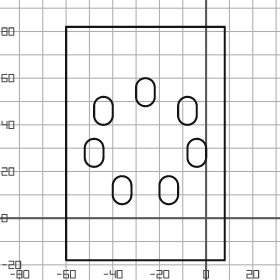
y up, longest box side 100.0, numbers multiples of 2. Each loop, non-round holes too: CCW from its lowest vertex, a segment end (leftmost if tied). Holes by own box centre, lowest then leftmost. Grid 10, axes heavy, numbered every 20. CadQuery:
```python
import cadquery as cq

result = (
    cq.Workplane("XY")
    .moveTo(-60.0, -18.0)
    .lineTo(8.0, -18.0)
    .lineTo(8.0, 82.0)
    .lineTo(-60.0, 82.0)
    .close()
    .moveTo(-40.0, 10.0)
    .threePointArc((-36.0, 6.0), (-32.0, 10.0))
    .lineTo(-32.0, 14.0)
    .threePointArc((-36.0, 18.0), (-40.0, 14.0))
    .close()
    .moveTo(-20.0, 10.0)
    .threePointArc((-16.0, 6.0), (-12.0, 10.0))
    .lineTo(-12.0, 14.0)
    .threePointArc((-16.0, 18.0), (-20.0, 14.0))
    .close()
    .moveTo(-52.0, 26.0)
    .threePointArc((-48.0, 22.0), (-44.0, 26.0))
    .lineTo(-44.0, 30.0)
    .threePointArc((-48.0, 34.0), (-52.0, 30.0))
    .close()
    .moveTo(-8.0, 26.0)
    .threePointArc((-4.0, 22.0), (0.0, 26.0))
    .lineTo(0.0, 30.0)
    .threePointArc((-4.0, 34.0), (-8.0, 30.0))
    .close()
    .moveTo(-48.0, 44.0)
    .threePointArc((-44.0, 40.0), (-40.0, 44.0))
    .lineTo(-40.0, 48.0)
    .threePointArc((-44.0, 52.0), (-48.0, 48.0))
    .close()
    .moveTo(-12.0, 44.0)
    .threePointArc((-8.0, 40.0), (-4.0, 44.0))
    .lineTo(-4.0, 48.0)
    .threePointArc((-8.0, 52.0), (-12.0, 48.0))
    .close()
    .moveTo(-30.0, 52.0)
    .threePointArc((-26.0, 48.0), (-22.0, 52.0))
    .lineTo(-22.0, 56.0)
    .threePointArc((-26.0, 60.0), (-30.0, 56.0))
    .close()
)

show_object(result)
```